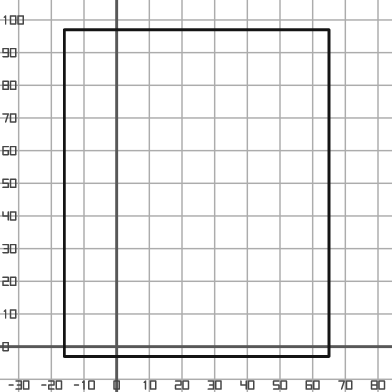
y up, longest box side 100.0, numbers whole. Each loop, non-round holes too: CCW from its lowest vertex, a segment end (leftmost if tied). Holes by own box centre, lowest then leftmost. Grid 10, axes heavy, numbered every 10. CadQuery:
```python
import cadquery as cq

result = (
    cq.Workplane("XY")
    .moveTo(-16.0, -3.0)
    .lineTo(65.0, -3.0)
    .lineTo(65.0, 97.0)
    .lineTo(-16.0, 97.0)
    .close()
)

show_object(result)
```